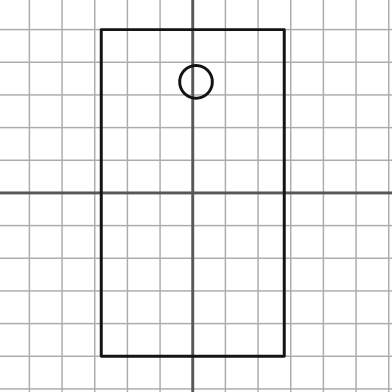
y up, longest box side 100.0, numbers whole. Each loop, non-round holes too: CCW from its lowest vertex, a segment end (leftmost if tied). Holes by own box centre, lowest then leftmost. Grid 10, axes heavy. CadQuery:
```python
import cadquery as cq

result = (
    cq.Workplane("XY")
    .moveTo(-28.0, -50.0)
    .lineTo(28.0, -50.0)
    .lineTo(28.0, 50.0)
    .lineTo(-28.0, 50.0)
    .close()
    .moveTo(1.0, 34.0)
    .circle(5.0)
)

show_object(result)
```